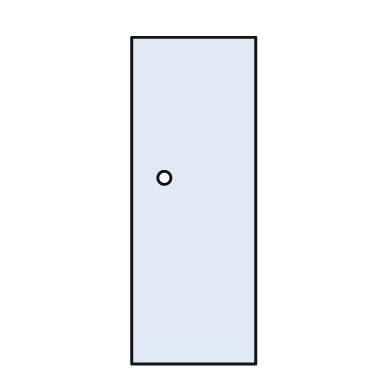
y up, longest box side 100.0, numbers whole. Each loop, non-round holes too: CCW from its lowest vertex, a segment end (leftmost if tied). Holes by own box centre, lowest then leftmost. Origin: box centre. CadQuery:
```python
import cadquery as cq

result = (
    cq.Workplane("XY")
    .moveTo(-19.0, -50.0)
    .lineTo(19.0, -50.0)
    .lineTo(19.0, 50.0)
    .lineTo(-19.0, 50.0)
    .close()
    .moveTo(-9.0, 7.0)
    .circle(2.0)
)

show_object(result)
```